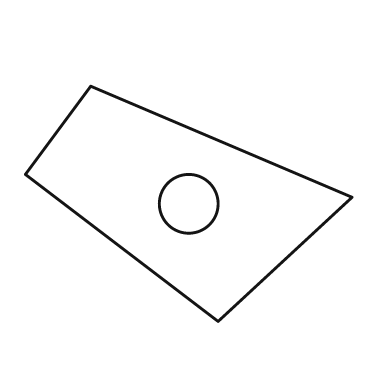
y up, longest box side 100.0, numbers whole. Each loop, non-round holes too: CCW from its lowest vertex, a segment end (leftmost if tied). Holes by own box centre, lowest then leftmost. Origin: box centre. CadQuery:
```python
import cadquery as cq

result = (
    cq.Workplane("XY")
    .moveTo(9.0, -36.0)
    .lineTo(50.0, 2.0)
    .lineTo(-30.0, 36.0)
    .lineTo(-50.0, 9.0)
    .close()
    .moveTo(0.0, 0.0)
    .circle(9.0)
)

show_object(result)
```